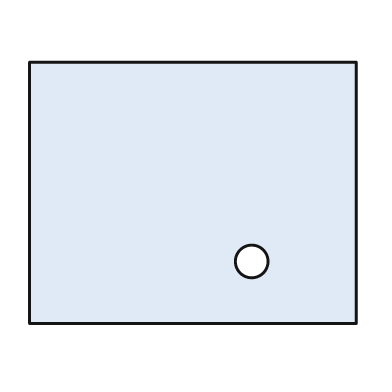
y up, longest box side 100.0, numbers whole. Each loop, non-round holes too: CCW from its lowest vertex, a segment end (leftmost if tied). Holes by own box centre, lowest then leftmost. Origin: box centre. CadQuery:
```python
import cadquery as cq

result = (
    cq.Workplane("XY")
    .moveTo(-50.0, -40.0)
    .lineTo(50.0, -40.0)
    .lineTo(50.0, 40.0)
    .lineTo(-50.0, 40.0)
    .close()
    .moveTo(18.0, -21.0)
    .circle(5.0)
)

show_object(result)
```